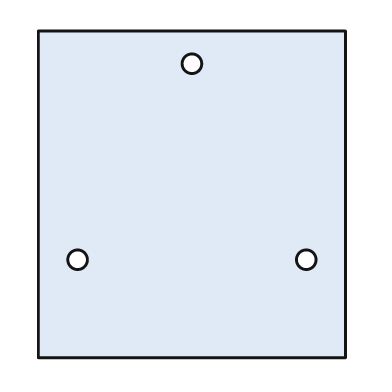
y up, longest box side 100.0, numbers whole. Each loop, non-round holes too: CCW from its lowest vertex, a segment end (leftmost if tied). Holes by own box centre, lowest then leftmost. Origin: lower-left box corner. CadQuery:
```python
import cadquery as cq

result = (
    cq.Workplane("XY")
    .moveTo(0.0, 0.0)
    .lineTo(94.0, 0.0)
    .lineTo(94.0, 100.0)
    .lineTo(0.0, 100.0)
    .close()
    .moveTo(12.0, 30.0)
    .circle(3.0)
    .moveTo(82.0, 30.0)
    .circle(3.0)
    .moveTo(47.0, 90.0)
    .circle(3.0)
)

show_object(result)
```